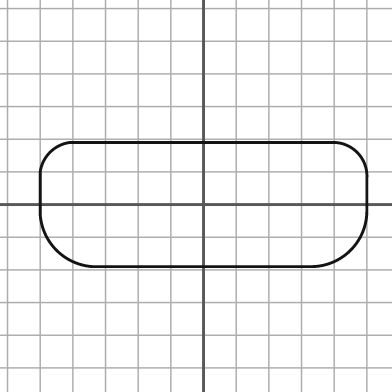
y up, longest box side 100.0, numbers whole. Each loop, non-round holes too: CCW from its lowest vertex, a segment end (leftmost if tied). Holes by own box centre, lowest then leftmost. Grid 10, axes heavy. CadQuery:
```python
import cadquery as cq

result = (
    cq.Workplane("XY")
    .moveTo(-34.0, -19.0)
    .lineTo(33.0, -19.0)
    .threePointArc((45.0, -14.0), (50.0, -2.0))
    .lineTo(50.0, 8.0)
    .threePointArc((47.0, 16.0), (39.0, 19.0))
    .lineTo(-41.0, 19.0)
    .threePointArc((-47.0, 16.0), (-50.0, 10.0))
    .lineTo(-50.0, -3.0)
    .threePointArc((-45.0, -14.0), (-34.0, -19.0))
    .close()
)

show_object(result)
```